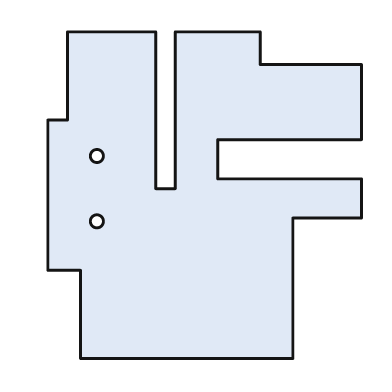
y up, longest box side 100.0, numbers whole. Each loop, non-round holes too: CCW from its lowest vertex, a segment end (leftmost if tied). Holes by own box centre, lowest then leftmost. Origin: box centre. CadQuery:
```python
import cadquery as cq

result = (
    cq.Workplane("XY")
    .moveTo(-38.0, -50.0)
    .lineTo(27.0, -50.0)
    .lineTo(27.0, -7.0)
    .lineTo(48.0, -7.0)
    .lineTo(48.0, 5.0)
    .lineTo(4.0, 5.0)
    .lineTo(4.0, 17.0)
    .lineTo(48.0, 17.0)
    .lineTo(48.0, 40.0)
    .lineTo(17.0, 40.0)
    .lineTo(17.0, 50.0)
    .lineTo(-9.0, 50.0)
    .lineTo(-9.0, 2.0)
    .lineTo(-15.0, 2.0)
    .lineTo(-15.0, 50.0)
    .lineTo(-42.0, 50.0)
    .lineTo(-42.0, 23.0)
    .lineTo(-48.0, 23.0)
    .lineTo(-48.0, -23.0)
    .lineTo(-38.0, -23.0)
    .close()
    .moveTo(-33.0, -8.0)
    .circle(2.0)
    .moveTo(-33.0, 12.0)
    .circle(2.0)
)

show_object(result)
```